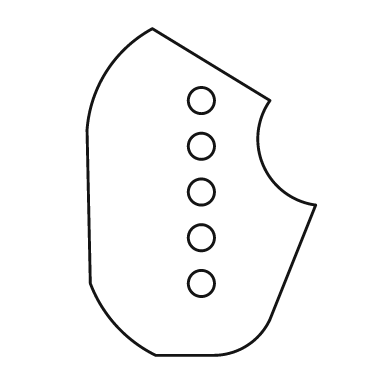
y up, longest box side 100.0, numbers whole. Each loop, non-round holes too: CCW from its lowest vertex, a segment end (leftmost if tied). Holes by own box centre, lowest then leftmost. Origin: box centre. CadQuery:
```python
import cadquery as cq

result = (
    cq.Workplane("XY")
    .moveTo(-14.0, -50.0)
    .lineTo(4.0, -50.0)
    .threePointArc((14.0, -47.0), (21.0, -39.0))
    .lineTo(35.0, -4.0)
    .threePointArc((19.0, 8.0), (21.0, 28.0))
    .lineTo(-15.0, 50.0)
    .threePointArc((-29.0, 37.0), (-35.0, 19.0))
    .lineTo(-34.0, -28.0)
    .threePointArc((-26.0, -41.0), (-14.0, -50.0))
    .close()
    .moveTo(0.0, -28.0)
    .circle(4.0)
    .moveTo(0.0, -14.0)
    .circle(4.0)
    .moveTo(0.0, 0.0)
    .circle(4.0)
    .moveTo(0.0, 14.0)
    .circle(4.0)
    .moveTo(0.0, 28.0)
    .circle(4.0)
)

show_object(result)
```